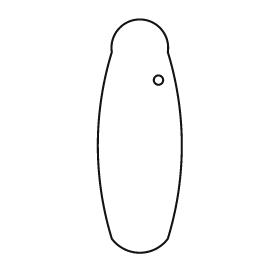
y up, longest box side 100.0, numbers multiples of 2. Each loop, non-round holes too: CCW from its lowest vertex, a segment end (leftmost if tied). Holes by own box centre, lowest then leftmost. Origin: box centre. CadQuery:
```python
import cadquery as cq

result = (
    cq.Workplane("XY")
    .moveTo(-12.0, -44.0)
    .threePointArc((0.0, -50.0), (12.0, -44.0))
    .threePointArc((18.0, -4.0), (12.0, 36.0))
    .threePointArc((0.0, 50.0), (-12.0, 36.0))
    .threePointArc((-18.0, -4.0), (-12.0, -44.0))
    .close()
    .moveTo(8.0, 24.0)
    .circle(2.0)
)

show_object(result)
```